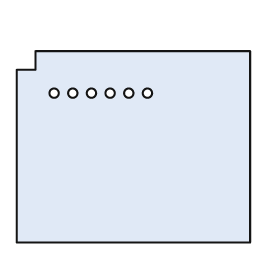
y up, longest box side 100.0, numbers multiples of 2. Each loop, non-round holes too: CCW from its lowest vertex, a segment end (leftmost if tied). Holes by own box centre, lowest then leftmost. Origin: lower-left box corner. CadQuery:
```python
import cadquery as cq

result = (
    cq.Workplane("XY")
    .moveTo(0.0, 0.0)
    .lineTo(100.0, 0.0)
    .lineTo(100.0, 82.0)
    .lineTo(8.0, 82.0)
    .lineTo(8.0, 74.0)
    .lineTo(0.0, 74.0)
    .close()
    .moveTo(16.0, 64.0)
    .circle(2.0)
    .moveTo(24.0, 64.0)
    .circle(2.0)
    .moveTo(32.0, 64.0)
    .circle(2.0)
    .moveTo(40.0, 64.0)
    .circle(2.0)
    .moveTo(48.0, 64.0)
    .circle(2.0)
    .moveTo(56.0, 64.0)
    .circle(2.0)
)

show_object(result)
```